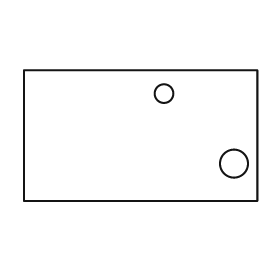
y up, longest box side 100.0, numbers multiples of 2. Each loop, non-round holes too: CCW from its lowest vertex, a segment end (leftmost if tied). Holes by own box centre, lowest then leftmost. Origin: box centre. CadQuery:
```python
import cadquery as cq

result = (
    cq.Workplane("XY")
    .moveTo(-50.0, -28.0)
    .lineTo(50.0, -28.0)
    .lineTo(50.0, 28.0)
    .lineTo(-50.0, 28.0)
    .close()
    .moveTo(40.0, -12.0)
    .circle(6.0)
    .moveTo(10.0, 18.0)
    .circle(4.0)
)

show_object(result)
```